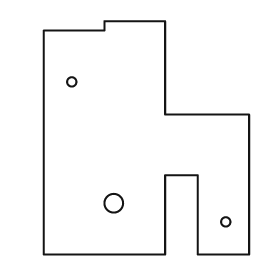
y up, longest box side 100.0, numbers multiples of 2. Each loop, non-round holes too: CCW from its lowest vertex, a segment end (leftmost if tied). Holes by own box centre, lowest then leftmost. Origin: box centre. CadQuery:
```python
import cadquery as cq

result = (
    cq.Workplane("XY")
    .moveTo(-44.0, -50.0)
    .lineTo(8.0, -50.0)
    .lineTo(8.0, -16.0)
    .lineTo(22.0, -16.0)
    .lineTo(22.0, -50.0)
    .lineTo(44.0, -50.0)
    .lineTo(44.0, 10.0)
    .lineTo(8.0, 10.0)
    .lineTo(8.0, 50.0)
    .lineTo(-18.0, 50.0)
    .lineTo(-18.0, 46.0)
    .lineTo(-44.0, 46.0)
    .close()
    .moveTo(34.0, -36.0)
    .circle(2.0)
    .moveTo(-14.0, -28.0)
    .circle(4.0)
    .moveTo(-32.0, 24.0)
    .circle(2.0)
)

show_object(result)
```